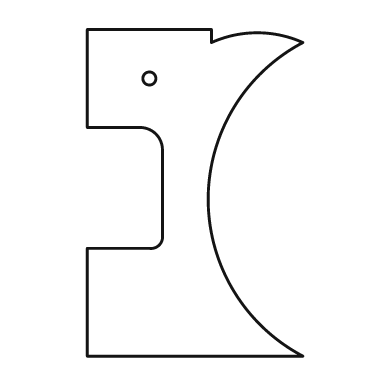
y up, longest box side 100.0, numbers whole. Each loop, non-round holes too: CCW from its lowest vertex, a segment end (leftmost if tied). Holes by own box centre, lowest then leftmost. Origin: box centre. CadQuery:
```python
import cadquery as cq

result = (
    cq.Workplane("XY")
    .moveTo(-33.0, -50.0)
    .lineTo(33.0, -50.0)
    .threePointArc((4.0, -2.0), (33.0, 46.0))
    .threePointArc((19.0, 49.0), (5.0, 46.0))
    .lineTo(5.0, 50.0)
    .lineTo(-33.0, 50.0)
    .lineTo(-33.0, 20.0)
    .lineTo(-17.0, 20.0)
    .threePointArc((-12.0, 18.0), (-10.0, 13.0))
    .lineTo(-10.0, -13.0)
    .threePointArc((-11.0, -16.0), (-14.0, -17.0))
    .lineTo(-33.0, -17.0)
    .close()
    .moveTo(-14.0, 35.0)
    .circle(2.0)
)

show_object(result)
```